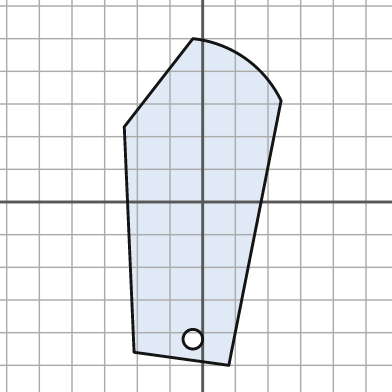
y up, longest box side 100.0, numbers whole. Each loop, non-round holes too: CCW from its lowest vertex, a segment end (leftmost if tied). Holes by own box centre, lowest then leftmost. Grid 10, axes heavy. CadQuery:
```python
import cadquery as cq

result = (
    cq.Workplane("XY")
    .moveTo(8.0, -50.0)
    .lineTo(24.0, 31.0)
    .threePointArc((13.0, 44.0), (-3.0, 50.0))
    .lineTo(-24.0, 23.0)
    .lineTo(-21.0, -46.0)
    .close()
    .moveTo(-3.0, -42.0)
    .circle(3.0)
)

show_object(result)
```